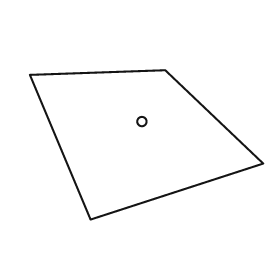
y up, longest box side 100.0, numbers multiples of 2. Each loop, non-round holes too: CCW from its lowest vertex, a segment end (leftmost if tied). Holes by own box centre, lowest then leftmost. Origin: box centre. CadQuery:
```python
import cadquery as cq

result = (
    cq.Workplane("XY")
    .moveTo(-24.0, -32.0)
    .lineTo(50.0, -8.0)
    .lineTo(8.0, 32.0)
    .lineTo(-50.0, 30.0)
    .close()
    .moveTo(-2.0, 10.0)
    .circle(2.0)
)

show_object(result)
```